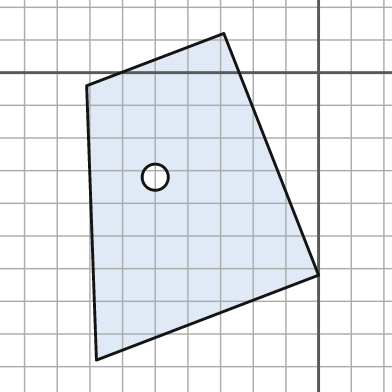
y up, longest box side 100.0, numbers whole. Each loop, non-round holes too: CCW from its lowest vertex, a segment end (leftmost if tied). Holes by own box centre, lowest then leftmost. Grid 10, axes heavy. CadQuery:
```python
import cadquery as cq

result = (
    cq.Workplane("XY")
    .moveTo(-68.0, -88.0)
    .lineTo(0.0, -62.0)
    .lineTo(-29.0, 12.0)
    .lineTo(-71.0, -4.0)
    .close()
    .moveTo(-50.0, -32.0)
    .circle(4.0)
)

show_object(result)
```